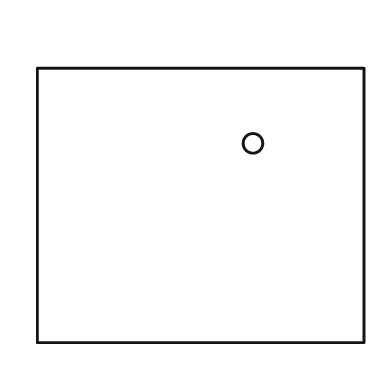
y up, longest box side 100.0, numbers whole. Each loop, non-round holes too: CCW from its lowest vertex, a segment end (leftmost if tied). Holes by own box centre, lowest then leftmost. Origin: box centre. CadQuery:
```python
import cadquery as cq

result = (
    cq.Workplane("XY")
    .moveTo(-50.0, -42.0)
    .lineTo(50.0, -42.0)
    .lineTo(50.0, 42.0)
    .lineTo(-50.0, 42.0)
    .close()
    .moveTo(16.0, 19.0)
    .circle(3.0)
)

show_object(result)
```